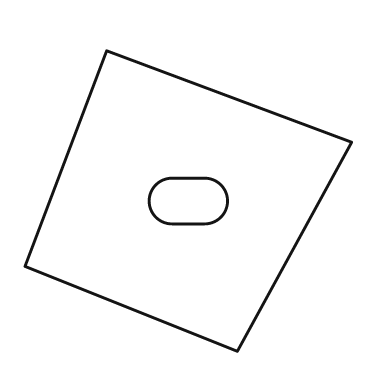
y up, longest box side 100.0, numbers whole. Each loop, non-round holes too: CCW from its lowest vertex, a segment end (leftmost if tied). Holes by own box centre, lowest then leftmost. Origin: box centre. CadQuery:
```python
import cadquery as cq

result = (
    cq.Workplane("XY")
    .moveTo(15.0, -46.0)
    .lineTo(50.0, 18.0)
    .lineTo(-25.0, 46.0)
    .lineTo(-50.0, -20.0)
    .close()
    .moveTo(-5.0, -7.0)
    .lineTo(5.0, -7.0)
    .threePointArc((12.0, 0.0), (5.0, 7.0))
    .lineTo(-5.0, 7.0)
    .threePointArc((-12.0, 0.0), (-5.0, -7.0))
    .close()
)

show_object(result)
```